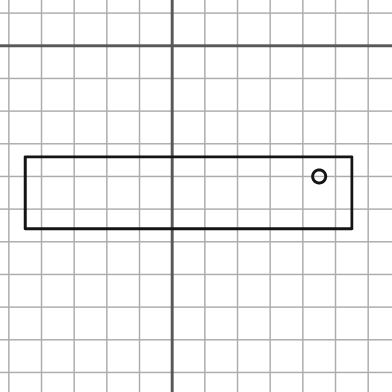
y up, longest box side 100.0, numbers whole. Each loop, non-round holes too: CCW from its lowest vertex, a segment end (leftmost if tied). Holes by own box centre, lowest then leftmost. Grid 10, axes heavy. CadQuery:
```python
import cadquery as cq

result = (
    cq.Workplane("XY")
    .moveTo(-45.0, -56.0)
    .lineTo(55.0, -56.0)
    .lineTo(55.0, -34.0)
    .lineTo(-45.0, -34.0)
    .close()
    .moveTo(45.0, -40.0)
    .circle(2.0)
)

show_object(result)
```